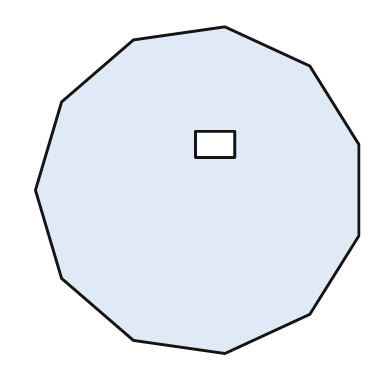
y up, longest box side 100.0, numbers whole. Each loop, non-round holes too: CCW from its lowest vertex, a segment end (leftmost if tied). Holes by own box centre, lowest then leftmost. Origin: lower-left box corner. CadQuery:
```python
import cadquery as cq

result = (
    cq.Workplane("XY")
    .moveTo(58.0, 0.0)
    .lineTo(84.0, 12.0)
    .lineTo(99.0, 36.0)
    .lineTo(99.0, 64.0)
    .lineTo(84.0, 88.0)
    .lineTo(58.0, 100.0)
    .lineTo(30.0, 96.0)
    .lineTo(8.0, 77.0)
    .lineTo(0.0, 50.0)
    .lineTo(8.0, 23.0)
    .lineTo(30.0, 4.0)
    .close()
    .moveTo(49.0, 60.0)
    .lineTo(61.0, 60.0)
    .lineTo(61.0, 68.0)
    .lineTo(49.0, 68.0)
    .close()
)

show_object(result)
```